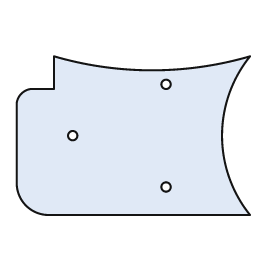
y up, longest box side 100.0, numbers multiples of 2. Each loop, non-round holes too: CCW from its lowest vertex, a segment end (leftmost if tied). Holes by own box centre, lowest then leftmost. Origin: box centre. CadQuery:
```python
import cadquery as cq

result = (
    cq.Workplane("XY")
    .moveTo(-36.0, -34.0)
    .lineTo(50.0, -34.0)
    .threePointArc((38.0, 0.0), (50.0, 34.0))
    .threePointArc((8.0, 28.0), (-34.0, 34.0))
    .lineTo(-34.0, 20.0)
    .lineTo(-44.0, 20.0)
    .threePointArc((-48.0, 18.0), (-50.0, 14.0))
    .lineTo(-50.0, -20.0)
    .threePointArc((-46.0, -30.0), (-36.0, -34.0))
    .close()
    .moveTo(14.0, -22.0)
    .circle(2.0)
    .moveTo(-26.0, 0.0)
    .circle(2.0)
    .moveTo(14.0, 22.0)
    .circle(2.0)
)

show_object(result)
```